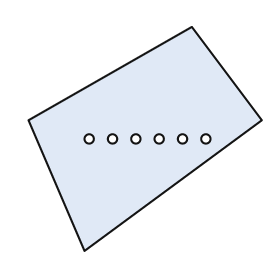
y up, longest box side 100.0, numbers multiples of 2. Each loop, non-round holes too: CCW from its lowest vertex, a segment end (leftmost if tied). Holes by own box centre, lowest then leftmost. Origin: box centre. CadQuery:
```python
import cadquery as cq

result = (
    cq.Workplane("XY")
    .moveTo(-26.0, -48.0)
    .lineTo(50.0, 8.0)
    .lineTo(20.0, 48.0)
    .lineTo(-50.0, 8.0)
    .close()
    .moveTo(-24.0, 0.0)
    .circle(2.0)
    .moveTo(-14.0, 0.0)
    .circle(2.0)
    .moveTo(-4.0, 0.0)
    .circle(2.0)
    .moveTo(6.0, 0.0)
    .circle(2.0)
    .moveTo(16.0, 0.0)
    .circle(2.0)
    .moveTo(26.0, 0.0)
    .circle(2.0)
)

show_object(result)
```